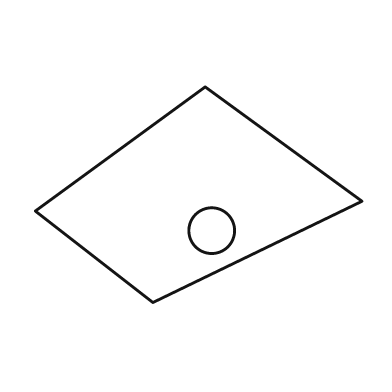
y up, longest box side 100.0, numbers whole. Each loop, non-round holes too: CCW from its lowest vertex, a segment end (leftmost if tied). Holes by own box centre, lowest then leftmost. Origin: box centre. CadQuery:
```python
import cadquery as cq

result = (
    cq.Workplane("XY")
    .moveTo(-14.0, -33.0)
    .lineTo(50.0, -2.0)
    .lineTo(2.0, 33.0)
    .lineTo(-50.0, -5.0)
    .close()
    .moveTo(4.0, -11.0)
    .circle(7.0)
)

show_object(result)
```